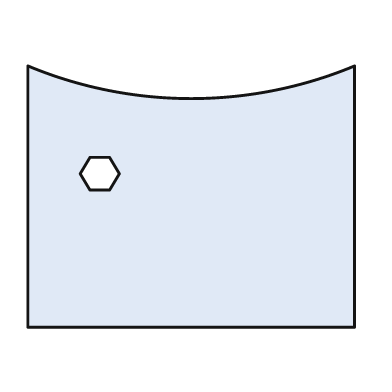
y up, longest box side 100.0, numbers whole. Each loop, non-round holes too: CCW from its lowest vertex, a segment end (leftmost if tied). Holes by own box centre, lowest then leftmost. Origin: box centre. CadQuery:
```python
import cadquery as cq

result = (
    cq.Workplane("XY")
    .moveTo(-50.0, -40.0)
    .lineTo(50.0, -40.0)
    .lineTo(50.0, 40.0)
    .threePointArc((0.0, 30.0), (-50.0, 40.0))
    .close()
    .moveTo(-31.0, 2.0)
    .lineTo(-25.0, 2.0)
    .lineTo(-22.0, 7.0)
    .lineTo(-25.0, 12.0)
    .lineTo(-31.0, 12.0)
    .lineTo(-34.0, 7.0)
    .close()
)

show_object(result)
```